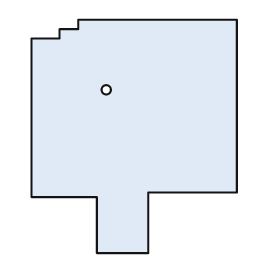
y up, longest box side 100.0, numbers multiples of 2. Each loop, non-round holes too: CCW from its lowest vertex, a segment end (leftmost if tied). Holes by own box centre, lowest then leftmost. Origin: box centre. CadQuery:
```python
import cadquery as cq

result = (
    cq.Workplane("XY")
    .moveTo(-16.0, -50.0)
    .lineTo(6.0, -50.0)
    .lineTo(6.0, -24.0)
    .lineTo(44.0, -24.0)
    .lineTo(44.0, 50.0)
    .lineTo(-24.0, 50.0)
    .lineTo(-24.0, 46.0)
    .lineTo(-32.0, 46.0)
    .lineTo(-32.0, 42.0)
    .lineTo(-44.0, 42.0)
    .lineTo(-44.0, -26.0)
    .lineTo(-16.0, -26.0)
    .close()
    .moveTo(-12.0, 20.0)
    .circle(2.0)
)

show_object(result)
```